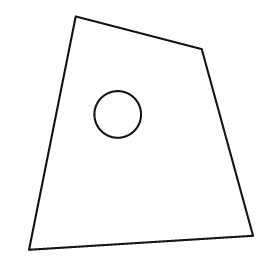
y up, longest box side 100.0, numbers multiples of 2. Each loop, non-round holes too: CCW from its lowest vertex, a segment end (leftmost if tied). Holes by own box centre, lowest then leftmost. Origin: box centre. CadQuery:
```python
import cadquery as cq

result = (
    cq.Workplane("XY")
    .moveTo(-48.0, -50.0)
    .lineTo(48.0, -44.0)
    .lineTo(26.0, 36.0)
    .lineTo(-28.0, 50.0)
    .close()
    .moveTo(-10.0, 8.0)
    .circle(10.0)
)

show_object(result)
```